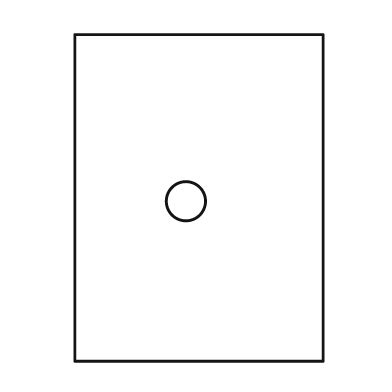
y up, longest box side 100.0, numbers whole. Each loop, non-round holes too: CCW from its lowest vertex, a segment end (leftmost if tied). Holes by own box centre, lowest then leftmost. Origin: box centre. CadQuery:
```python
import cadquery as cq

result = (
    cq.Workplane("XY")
    .moveTo(-38.0, -50.0)
    .lineTo(38.0, -50.0)
    .lineTo(38.0, 50.0)
    .lineTo(-38.0, 50.0)
    .close()
    .moveTo(-4.0, -1.0)
    .circle(6.0)
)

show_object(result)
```